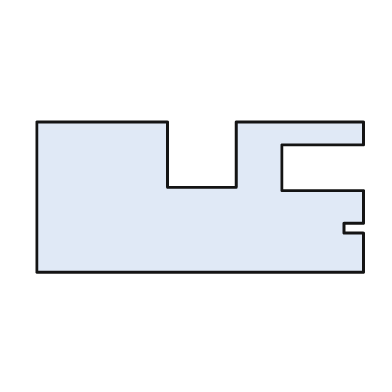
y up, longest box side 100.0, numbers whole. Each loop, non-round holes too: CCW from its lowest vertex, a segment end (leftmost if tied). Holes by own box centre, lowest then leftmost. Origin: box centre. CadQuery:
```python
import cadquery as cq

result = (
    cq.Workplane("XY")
    .moveTo(-50.0, -23.0)
    .lineTo(50.0, -23.0)
    .lineTo(50.0, -11.0)
    .lineTo(44.0, -11.0)
    .lineTo(44.0, -8.0)
    .lineTo(50.0, -8.0)
    .lineTo(50.0, 2.0)
    .lineTo(25.0, 2.0)
    .lineTo(25.0, 16.0)
    .lineTo(50.0, 16.0)
    .lineTo(50.0, 23.0)
    .lineTo(11.0, 23.0)
    .lineTo(11.0, 3.0)
    .lineTo(-10.0, 3.0)
    .lineTo(-10.0, 23.0)
    .lineTo(-50.0, 23.0)
    .close()
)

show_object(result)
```